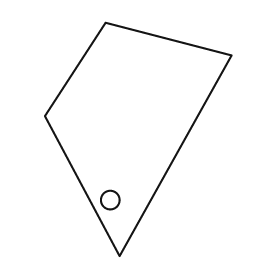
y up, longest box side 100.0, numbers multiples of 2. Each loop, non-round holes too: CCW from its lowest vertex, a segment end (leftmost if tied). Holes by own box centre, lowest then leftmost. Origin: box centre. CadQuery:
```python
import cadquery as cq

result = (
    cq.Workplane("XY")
    .moveTo(-8.0, -50.0)
    .lineTo(40.0, 36.0)
    .lineTo(-14.0, 50.0)
    .lineTo(-40.0, 10.0)
    .close()
    .moveTo(-12.0, -26.0)
    .circle(4.0)
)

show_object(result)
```